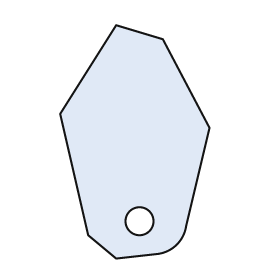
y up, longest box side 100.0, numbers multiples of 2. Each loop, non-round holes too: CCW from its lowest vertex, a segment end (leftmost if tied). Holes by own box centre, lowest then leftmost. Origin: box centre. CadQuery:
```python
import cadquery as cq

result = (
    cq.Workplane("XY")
    .moveTo(-8.0, -50.0)
    .lineTo(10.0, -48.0)
    .threePointArc((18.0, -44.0), (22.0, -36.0))
    .lineTo(32.0, 6.0)
    .lineTo(12.0, 44.0)
    .lineTo(-8.0, 50.0)
    .lineTo(-32.0, 12.0)
    .lineTo(-20.0, -40.0)
    .close()
    .moveTo(2.0, -34.0)
    .circle(6.0)
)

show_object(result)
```